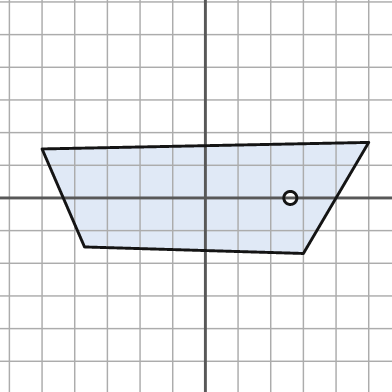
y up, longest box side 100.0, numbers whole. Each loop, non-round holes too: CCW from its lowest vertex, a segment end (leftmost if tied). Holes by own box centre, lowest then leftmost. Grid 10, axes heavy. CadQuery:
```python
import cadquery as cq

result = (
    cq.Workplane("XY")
    .moveTo(30.0, -17.0)
    .lineTo(50.0, 17.0)
    .lineTo(-50.0, 15.0)
    .lineTo(-37.0, -15.0)
    .close()
    .moveTo(26.0, 0.0)
    .circle(2.0)
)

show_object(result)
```